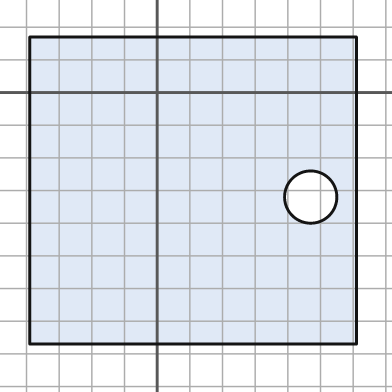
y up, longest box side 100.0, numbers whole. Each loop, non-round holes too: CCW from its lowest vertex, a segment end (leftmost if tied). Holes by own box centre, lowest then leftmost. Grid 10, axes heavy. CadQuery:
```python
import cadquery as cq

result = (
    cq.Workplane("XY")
    .moveTo(-39.0, -77.0)
    .lineTo(61.0, -77.0)
    .lineTo(61.0, 17.0)
    .lineTo(-39.0, 17.0)
    .close()
    .moveTo(47.0, -32.0)
    .circle(8.0)
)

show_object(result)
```